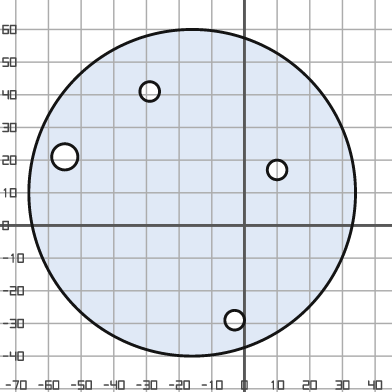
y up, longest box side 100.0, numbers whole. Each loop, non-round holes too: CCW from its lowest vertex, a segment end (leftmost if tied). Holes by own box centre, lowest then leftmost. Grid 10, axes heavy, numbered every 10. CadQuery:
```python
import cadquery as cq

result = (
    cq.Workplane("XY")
    .moveTo(-16.0, 10.0)
    .circle(50.0)
    .moveTo(-3.0, -29.0)
    .circle(3.0)
    .moveTo(10.0, 17.0)
    .circle(3.0)
    .moveTo(-55.0, 21.0)
    .circle(4.0)
    .moveTo(-29.0, 41.0)
    .circle(3.0)
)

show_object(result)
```